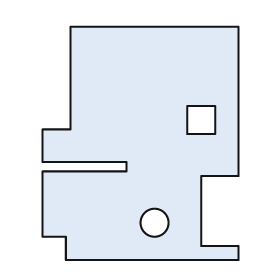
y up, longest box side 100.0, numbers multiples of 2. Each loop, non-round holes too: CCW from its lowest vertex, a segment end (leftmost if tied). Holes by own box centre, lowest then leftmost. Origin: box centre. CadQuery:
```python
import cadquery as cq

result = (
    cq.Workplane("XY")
    .moveTo(-32.0, -50.0)
    .lineTo(42.0, -50.0)
    .lineTo(42.0, -44.0)
    .lineTo(26.0, -44.0)
    .lineTo(26.0, -14.0)
    .lineTo(42.0, -14.0)
    .lineTo(42.0, 50.0)
    .lineTo(-30.0, 50.0)
    .lineTo(-30.0, 6.0)
    .lineTo(-42.0, 6.0)
    .lineTo(-42.0, -8.0)
    .lineTo(-6.0, -8.0)
    .lineTo(-6.0, -12.0)
    .lineTo(-42.0, -12.0)
    .lineTo(-42.0, -40.0)
    .lineTo(-32.0, -40.0)
    .close()
    .moveTo(6.0, -34.0)
    .circle(6.0)
    .moveTo(20.0, 4.0)
    .lineTo(32.0, 4.0)
    .lineTo(32.0, 16.0)
    .lineTo(20.0, 16.0)
    .close()
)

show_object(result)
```